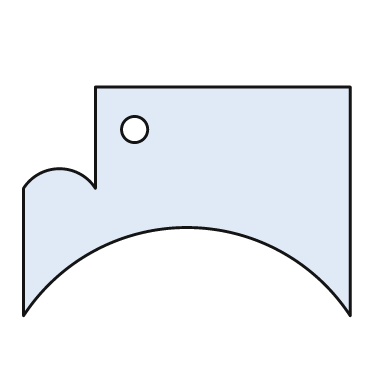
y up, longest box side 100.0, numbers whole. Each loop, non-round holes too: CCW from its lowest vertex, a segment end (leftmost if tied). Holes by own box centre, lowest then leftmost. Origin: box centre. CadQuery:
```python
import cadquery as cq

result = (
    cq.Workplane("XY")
    .moveTo(-50.0, -35.0)
    .threePointArc((0.0, -8.0), (50.0, -35.0))
    .lineTo(50.0, 35.0)
    .lineTo(-28.0, 35.0)
    .lineTo(-28.0, 4.0)
    .threePointArc((-39.0, 10.0), (-50.0, 4.0))
    .close()
    .moveTo(-16.0, 22.0)
    .circle(4.0)
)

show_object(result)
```